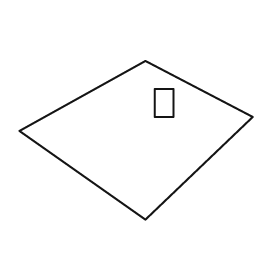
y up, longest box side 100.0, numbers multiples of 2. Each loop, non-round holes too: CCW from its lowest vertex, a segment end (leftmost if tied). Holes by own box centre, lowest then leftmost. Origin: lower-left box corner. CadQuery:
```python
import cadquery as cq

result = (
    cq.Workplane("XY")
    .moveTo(54.0, 0.0)
    .lineTo(100.0, 44.0)
    .lineTo(54.0, 68.0)
    .lineTo(0.0, 38.0)
    .close()
    .moveTo(58.0, 44.0)
    .lineTo(66.0, 44.0)
    .lineTo(66.0, 56.0)
    .lineTo(58.0, 56.0)
    .close()
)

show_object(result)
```